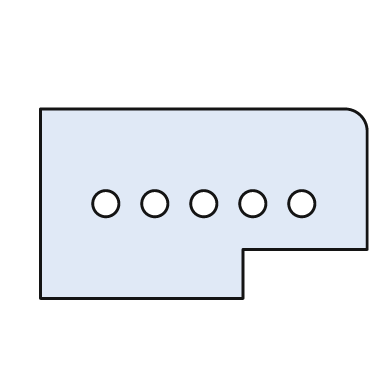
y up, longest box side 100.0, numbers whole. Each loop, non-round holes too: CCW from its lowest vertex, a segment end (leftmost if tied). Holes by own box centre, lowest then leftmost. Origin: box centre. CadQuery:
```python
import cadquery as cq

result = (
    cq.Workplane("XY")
    .moveTo(-50.0, -29.0)
    .lineTo(12.0, -29.0)
    .lineTo(12.0, -14.0)
    .lineTo(50.0, -14.0)
    .lineTo(50.0, 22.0)
    .threePointArc((48.0, 27.0), (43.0, 29.0))
    .lineTo(-50.0, 29.0)
    .close()
    .moveTo(-30.0, 0.0)
    .circle(4.0)
    .moveTo(-15.0, 0.0)
    .circle(4.0)
    .moveTo(0.0, 0.0)
    .circle(4.0)
    .moveTo(15.0, 0.0)
    .circle(4.0)
    .moveTo(30.0, 0.0)
    .circle(4.0)
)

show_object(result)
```